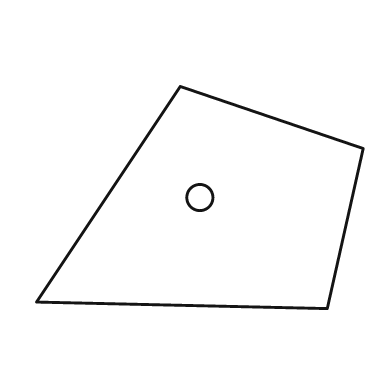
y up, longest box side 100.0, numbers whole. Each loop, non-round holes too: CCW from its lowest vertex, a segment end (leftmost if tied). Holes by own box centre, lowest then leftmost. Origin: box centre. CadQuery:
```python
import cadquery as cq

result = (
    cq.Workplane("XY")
    .moveTo(39.0, -34.0)
    .lineTo(50.0, 15.0)
    .lineTo(-6.0, 34.0)
    .lineTo(-50.0, -32.0)
    .close()
    .moveTo(0.0, 0.0)
    .circle(4.0)
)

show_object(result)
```